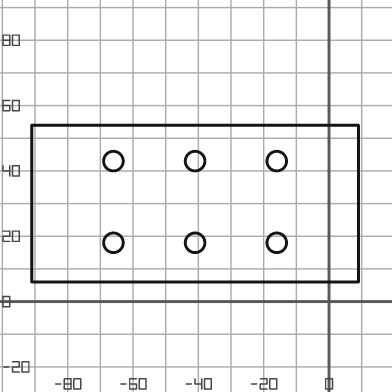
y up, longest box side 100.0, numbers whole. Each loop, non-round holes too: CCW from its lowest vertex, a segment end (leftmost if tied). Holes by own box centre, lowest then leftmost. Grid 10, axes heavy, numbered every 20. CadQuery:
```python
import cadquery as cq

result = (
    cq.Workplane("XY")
    .moveTo(-91.0, 6.0)
    .lineTo(9.0, 6.0)
    .lineTo(9.0, 54.0)
    .lineTo(-91.0, 54.0)
    .close()
    .moveTo(-66.0, 18.0)
    .circle(3.0)
    .moveTo(-41.0, 18.0)
    .circle(3.0)
    .moveTo(-16.0, 18.0)
    .circle(3.0)
    .moveTo(-66.0, 43.0)
    .circle(3.0)
    .moveTo(-41.0, 43.0)
    .circle(3.0)
    .moveTo(-16.0, 43.0)
    .circle(3.0)
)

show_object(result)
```